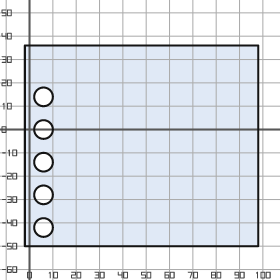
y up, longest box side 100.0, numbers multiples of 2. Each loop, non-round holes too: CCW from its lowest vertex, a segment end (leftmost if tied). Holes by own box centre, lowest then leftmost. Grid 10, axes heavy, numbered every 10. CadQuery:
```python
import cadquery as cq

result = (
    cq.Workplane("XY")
    .moveTo(-2.0, -50.0)
    .lineTo(98.0, -50.0)
    .lineTo(98.0, 36.0)
    .lineTo(-2.0, 36.0)
    .close()
    .moveTo(6.0, -42.0)
    .circle(4.0)
    .moveTo(6.0, -28.0)
    .circle(4.0)
    .moveTo(6.0, -14.0)
    .circle(4.0)
    .moveTo(6.0, 0.0)
    .circle(4.0)
    .moveTo(6.0, 14.0)
    .circle(4.0)
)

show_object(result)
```